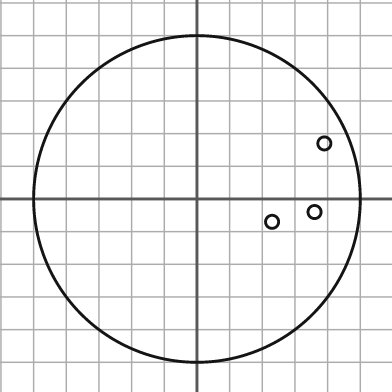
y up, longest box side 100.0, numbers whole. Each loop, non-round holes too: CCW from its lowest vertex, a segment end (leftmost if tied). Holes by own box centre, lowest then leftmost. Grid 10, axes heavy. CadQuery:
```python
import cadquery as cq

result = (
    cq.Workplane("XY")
    .moveTo(0.0, 0.0)
    .circle(50.0)
    .moveTo(23.0, -7.0)
    .circle(2.0)
    .moveTo(36.0, -4.0)
    .circle(2.0)
    .moveTo(39.0, 17.0)
    .circle(2.0)
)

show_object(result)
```